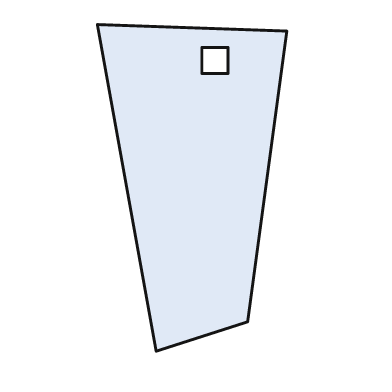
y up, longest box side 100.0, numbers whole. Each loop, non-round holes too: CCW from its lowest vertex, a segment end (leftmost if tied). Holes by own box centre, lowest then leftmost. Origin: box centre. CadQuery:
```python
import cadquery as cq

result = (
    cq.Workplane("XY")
    .moveTo(-11.0, -50.0)
    .lineTo(17.0, -41.0)
    .lineTo(29.0, 48.0)
    .lineTo(-29.0, 50.0)
    .close()
    .moveTo(3.0, 35.0)
    .lineTo(11.0, 35.0)
    .lineTo(11.0, 43.0)
    .lineTo(3.0, 43.0)
    .close()
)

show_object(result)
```